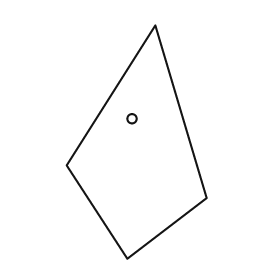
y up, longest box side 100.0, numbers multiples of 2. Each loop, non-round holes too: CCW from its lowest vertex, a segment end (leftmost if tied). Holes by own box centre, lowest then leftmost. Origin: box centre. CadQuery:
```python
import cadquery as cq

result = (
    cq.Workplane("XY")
    .moveTo(-4.0, -50.0)
    .lineTo(30.0, -24.0)
    .lineTo(8.0, 50.0)
    .lineTo(-30.0, -10.0)
    .close()
    .moveTo(-2.0, 10.0)
    .circle(2.0)
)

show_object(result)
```